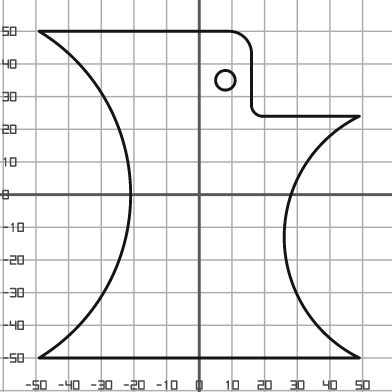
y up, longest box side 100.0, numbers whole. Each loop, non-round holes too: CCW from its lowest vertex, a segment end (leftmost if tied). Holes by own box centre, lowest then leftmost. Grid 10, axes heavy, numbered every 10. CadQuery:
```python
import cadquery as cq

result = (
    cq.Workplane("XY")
    .moveTo(-49.0, -50.0)
    .lineTo(49.0, -50.0)
    .threePointArc((26.0, -13.0), (49.0, 24.0))
    .lineTo(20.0, 24.0)
    .threePointArc((17.0, 25.0), (16.0, 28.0))
    .lineTo(16.0, 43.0)
    .threePointArc((14.0, 48.0), (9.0, 50.0))
    .lineTo(-49.0, 50.0)
    .threePointArc((-21.0, 0.0), (-49.0, -50.0))
    .close()
    .moveTo(8.0, 35.0)
    .circle(3.0)
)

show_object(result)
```